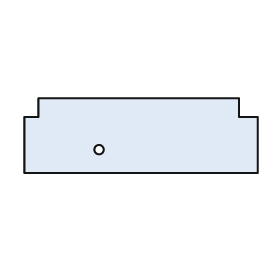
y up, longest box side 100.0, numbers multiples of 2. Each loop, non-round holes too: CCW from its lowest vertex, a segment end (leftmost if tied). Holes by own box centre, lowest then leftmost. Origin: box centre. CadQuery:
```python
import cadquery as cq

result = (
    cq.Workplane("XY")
    .moveTo(-50.0, -16.0)
    .lineTo(50.0, -16.0)
    .lineTo(50.0, 8.0)
    .lineTo(42.0, 8.0)
    .lineTo(42.0, 16.0)
    .lineTo(-44.0, 16.0)
    .lineTo(-44.0, 8.0)
    .lineTo(-50.0, 8.0)
    .close()
    .moveTo(-18.0, -6.0)
    .circle(2.0)
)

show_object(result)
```